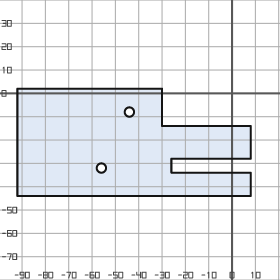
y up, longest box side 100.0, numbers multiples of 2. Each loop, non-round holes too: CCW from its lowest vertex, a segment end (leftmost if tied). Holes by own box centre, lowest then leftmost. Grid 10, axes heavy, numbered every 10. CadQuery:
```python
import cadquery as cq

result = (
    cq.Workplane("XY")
    .moveTo(-92.0, -44.0)
    .lineTo(8.0, -44.0)
    .lineTo(8.0, -34.0)
    .lineTo(-26.0, -34.0)
    .lineTo(-26.0, -28.0)
    .lineTo(8.0, -28.0)
    .lineTo(8.0, -14.0)
    .lineTo(-30.0, -14.0)
    .lineTo(-30.0, 2.0)
    .lineTo(-92.0, 2.0)
    .close()
    .moveTo(-56.0, -32.0)
    .circle(2.0)
    .moveTo(-44.0, -8.0)
    .circle(2.0)
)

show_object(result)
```